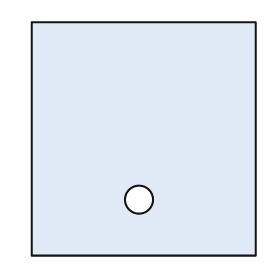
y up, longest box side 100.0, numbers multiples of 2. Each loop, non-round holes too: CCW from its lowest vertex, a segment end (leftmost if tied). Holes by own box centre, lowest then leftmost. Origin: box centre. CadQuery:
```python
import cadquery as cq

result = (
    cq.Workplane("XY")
    .moveTo(-48.0, -50.0)
    .lineTo(48.0, -50.0)
    .lineTo(48.0, 50.0)
    .lineTo(-48.0, 50.0)
    .close()
    .moveTo(-2.0, -26.0)
    .circle(6.0)
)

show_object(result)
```